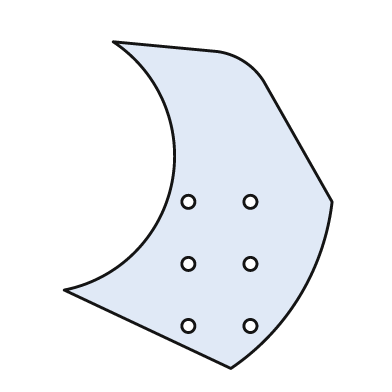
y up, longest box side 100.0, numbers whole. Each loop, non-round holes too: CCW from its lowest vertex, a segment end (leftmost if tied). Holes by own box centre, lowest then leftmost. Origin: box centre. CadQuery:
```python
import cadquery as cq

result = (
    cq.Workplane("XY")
    .moveTo(10.0, -50.0)
    .threePointArc((31.0, -28.0), (41.0, 1.0))
    .lineTo(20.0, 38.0)
    .threePointArc((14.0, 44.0), (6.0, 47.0))
    .lineTo(-26.0, 50.0)
    .threePointArc((-8.0, 7.0), (-41.0, -26.0))
    .close()
    .moveTo(-3.0, -37.0)
    .circle(2.0)
    .moveTo(16.0, -37.0)
    .circle(2.0)
    .moveTo(-3.0, -18.0)
    .circle(2.0)
    .moveTo(16.0, -18.0)
    .circle(2.0)
    .moveTo(-3.0, 1.0)
    .circle(2.0)
    .moveTo(16.0, 1.0)
    .circle(2.0)
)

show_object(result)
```